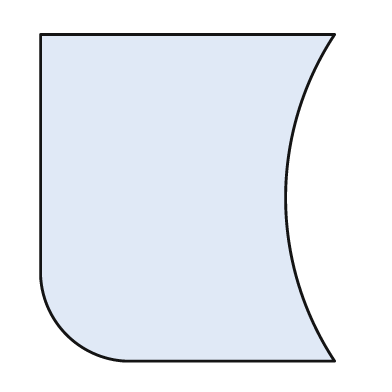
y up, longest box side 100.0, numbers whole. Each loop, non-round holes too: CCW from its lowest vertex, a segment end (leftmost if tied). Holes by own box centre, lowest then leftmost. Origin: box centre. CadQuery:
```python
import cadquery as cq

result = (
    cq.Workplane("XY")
    .moveTo(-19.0, -50.0)
    .lineTo(45.0, -50.0)
    .threePointArc((30.0, 0.0), (45.0, 50.0))
    .lineTo(-45.0, 50.0)
    .lineTo(-45.0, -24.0)
    .threePointArc((-37.0, -42.0), (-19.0, -50.0))
    .close()
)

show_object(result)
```